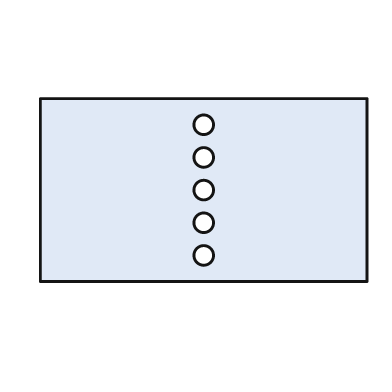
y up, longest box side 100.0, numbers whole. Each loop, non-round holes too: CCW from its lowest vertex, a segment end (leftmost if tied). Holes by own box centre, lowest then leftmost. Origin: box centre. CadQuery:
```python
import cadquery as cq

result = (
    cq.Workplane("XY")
    .moveTo(-50.0, -28.0)
    .lineTo(50.0, -28.0)
    .lineTo(50.0, 28.0)
    .lineTo(-50.0, 28.0)
    .close()
    .moveTo(0.0, -20.0)
    .circle(3.0)
    .moveTo(0.0, -10.0)
    .circle(3.0)
    .moveTo(0.0, 0.0)
    .circle(3.0)
    .moveTo(0.0, 10.0)
    .circle(3.0)
    .moveTo(0.0, 20.0)
    .circle(3.0)
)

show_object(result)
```